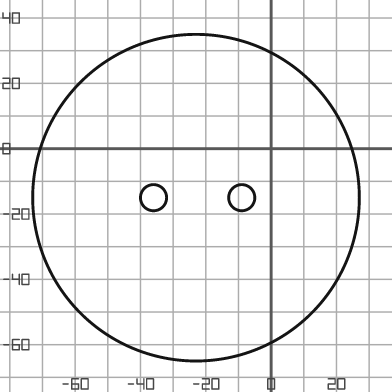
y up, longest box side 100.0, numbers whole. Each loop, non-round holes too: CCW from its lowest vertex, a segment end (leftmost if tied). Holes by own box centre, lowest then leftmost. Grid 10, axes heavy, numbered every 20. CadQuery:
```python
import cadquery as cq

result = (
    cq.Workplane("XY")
    .moveTo(-23.0, -15.0)
    .circle(50.0)
    .moveTo(-36.0, -15.0)
    .circle(4.0)
    .moveTo(-9.0, -15.0)
    .circle(4.0)
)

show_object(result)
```